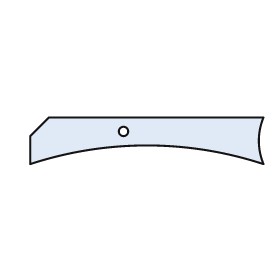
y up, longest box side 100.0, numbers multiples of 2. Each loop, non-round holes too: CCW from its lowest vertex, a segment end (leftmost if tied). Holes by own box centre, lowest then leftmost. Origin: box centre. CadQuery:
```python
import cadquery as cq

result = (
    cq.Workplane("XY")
    .moveTo(-50.0, -10.0)
    .threePointArc((0.0, -2.0), (50.0, -10.0))
    .threePointArc((48.0, 0.0), (50.0, 10.0))
    .lineTo(-42.0, 10.0)
    .lineTo(-50.0, 2.0)
    .close()
    .moveTo(-10.0, 4.0)
    .circle(2.0)
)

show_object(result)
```